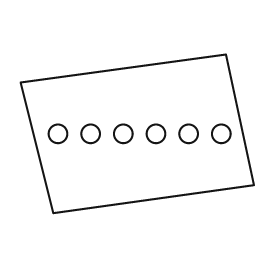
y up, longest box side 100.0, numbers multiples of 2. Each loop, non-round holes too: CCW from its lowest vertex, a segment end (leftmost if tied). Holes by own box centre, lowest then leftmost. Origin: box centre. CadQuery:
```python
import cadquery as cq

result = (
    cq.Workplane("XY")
    .moveTo(-36.0, -34.0)
    .lineTo(50.0, -22.0)
    .lineTo(38.0, 34.0)
    .lineTo(-50.0, 22.0)
    .close()
    .moveTo(-34.0, 0.0)
    .circle(4.0)
    .moveTo(-20.0, 0.0)
    .circle(4.0)
    .moveTo(-6.0, 0.0)
    .circle(4.0)
    .moveTo(8.0, 0.0)
    .circle(4.0)
    .moveTo(22.0, 0.0)
    .circle(4.0)
    .moveTo(36.0, 0.0)
    .circle(4.0)
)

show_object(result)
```